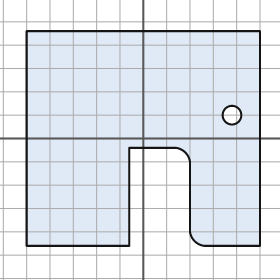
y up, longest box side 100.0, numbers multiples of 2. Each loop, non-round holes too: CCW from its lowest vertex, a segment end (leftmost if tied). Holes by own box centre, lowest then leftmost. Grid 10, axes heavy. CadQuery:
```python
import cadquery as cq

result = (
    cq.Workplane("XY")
    .moveTo(-50.0, -46.0)
    .lineTo(-6.0, -46.0)
    .lineTo(-6.0, -4.0)
    .lineTo(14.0, -4.0)
    .threePointArc((18.0, -6.0), (20.0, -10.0))
    .lineTo(20.0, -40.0)
    .threePointArc((22.0, -44.0), (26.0, -46.0))
    .lineTo(50.0, -46.0)
    .lineTo(50.0, 46.0)
    .lineTo(-50.0, 46.0)
    .close()
    .moveTo(38.0, 10.0)
    .circle(4.0)
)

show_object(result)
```